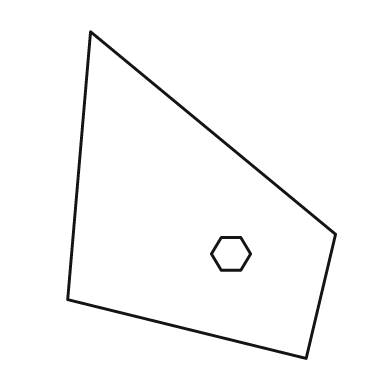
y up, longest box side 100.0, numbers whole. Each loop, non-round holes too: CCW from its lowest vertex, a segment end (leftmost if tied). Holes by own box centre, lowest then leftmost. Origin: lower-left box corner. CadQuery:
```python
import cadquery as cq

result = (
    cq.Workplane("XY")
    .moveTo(73.0, 0.0)
    .lineTo(82.0, 38.0)
    .lineTo(7.0, 100.0)
    .lineTo(0.0, 18.0)
    .close()
    .moveTo(47.0, 27.0)
    .lineTo(53.0, 27.0)
    .lineTo(56.0, 32.0)
    .lineTo(53.0, 37.0)
    .lineTo(47.0, 37.0)
    .lineTo(44.0, 32.0)
    .close()
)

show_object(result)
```